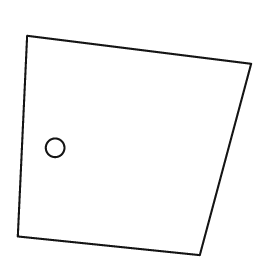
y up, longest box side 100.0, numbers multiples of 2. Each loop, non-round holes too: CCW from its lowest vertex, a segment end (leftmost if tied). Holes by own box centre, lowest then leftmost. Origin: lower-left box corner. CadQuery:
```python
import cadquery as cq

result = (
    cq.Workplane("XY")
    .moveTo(78.0, 0.0)
    .lineTo(100.0, 82.0)
    .lineTo(4.0, 94.0)
    .lineTo(0.0, 8.0)
    .close()
    .moveTo(16.0, 46.0)
    .circle(4.0)
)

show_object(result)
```